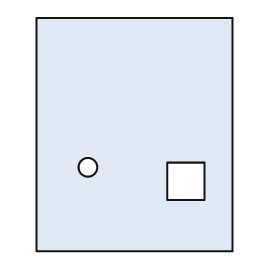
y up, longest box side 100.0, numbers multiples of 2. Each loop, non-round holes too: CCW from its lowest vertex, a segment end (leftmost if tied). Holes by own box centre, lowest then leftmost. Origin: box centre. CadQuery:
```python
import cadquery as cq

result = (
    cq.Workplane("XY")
    .moveTo(-42.0, -50.0)
    .lineTo(42.0, -50.0)
    .lineTo(42.0, 50.0)
    .lineTo(-42.0, 50.0)
    .close()
    .moveTo(14.0, -28.0)
    .lineTo(30.0, -28.0)
    .lineTo(30.0, -12.0)
    .lineTo(14.0, -12.0)
    .close()
    .moveTo(-20.0, -14.0)
    .circle(4.0)
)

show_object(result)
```